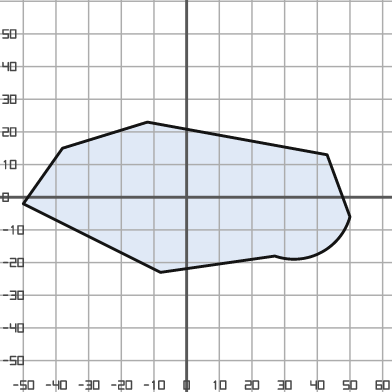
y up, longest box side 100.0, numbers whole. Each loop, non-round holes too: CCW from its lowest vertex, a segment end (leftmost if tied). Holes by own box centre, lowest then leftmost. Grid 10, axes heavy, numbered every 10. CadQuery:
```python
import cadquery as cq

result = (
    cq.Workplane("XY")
    .moveTo(-8.0, -23.0)
    .lineTo(27.0, -18.0)
    .threePointArc((41.0, -17.0), (50.0, -6.0))
    .lineTo(43.0, 13.0)
    .lineTo(-12.0, 23.0)
    .lineTo(-38.0, 15.0)
    .lineTo(-50.0, -2.0)
    .close()
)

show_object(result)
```